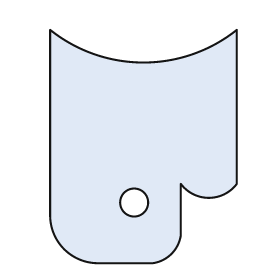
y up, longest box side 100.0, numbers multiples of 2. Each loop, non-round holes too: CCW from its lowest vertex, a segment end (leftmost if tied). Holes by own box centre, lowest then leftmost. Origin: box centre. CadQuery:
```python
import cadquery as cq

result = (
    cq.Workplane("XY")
    .moveTo(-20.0, -50.0)
    .lineTo(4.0, -50.0)
    .threePointArc((12.0, -46.0), (16.0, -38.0))
    .lineTo(16.0, -16.0)
    .threePointArc((28.0, -22.0), (40.0, -16.0))
    .lineTo(40.0, 50.0)
    .threePointArc((0.0, 36.0), (-40.0, 50.0))
    .lineTo(-40.0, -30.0)
    .threePointArc((-34.0, -44.0), (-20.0, -50.0))
    .close()
    .moveTo(-4.0, -24.0)
    .circle(6.0)
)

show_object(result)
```